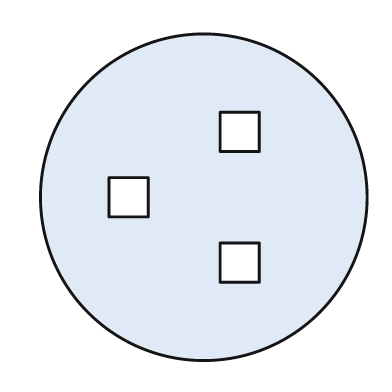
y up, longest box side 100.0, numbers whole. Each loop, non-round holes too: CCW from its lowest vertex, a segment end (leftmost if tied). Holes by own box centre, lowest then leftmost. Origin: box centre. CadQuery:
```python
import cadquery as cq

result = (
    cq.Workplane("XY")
    .moveTo(0.0, 0.0)
    .circle(50.0)
    .moveTo(5.0, -26.0)
    .lineTo(17.0, -26.0)
    .lineTo(17.0, -14.0)
    .lineTo(5.0, -14.0)
    .close()
    .moveTo(-29.0, -6.0)
    .lineTo(-17.0, -6.0)
    .lineTo(-17.0, 6.0)
    .lineTo(-29.0, 6.0)
    .close()
    .moveTo(5.0, 14.0)
    .lineTo(17.0, 14.0)
    .lineTo(17.0, 26.0)
    .lineTo(5.0, 26.0)
    .close()
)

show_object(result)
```